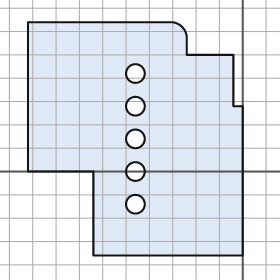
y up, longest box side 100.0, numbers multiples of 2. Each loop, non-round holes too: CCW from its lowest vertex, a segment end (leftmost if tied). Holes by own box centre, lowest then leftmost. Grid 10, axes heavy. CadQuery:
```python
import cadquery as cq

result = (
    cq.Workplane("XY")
    .moveTo(-64.0, -36.0)
    .lineTo(0.0, -36.0)
    .lineTo(0.0, 28.0)
    .lineTo(-4.0, 28.0)
    .lineTo(-4.0, 50.0)
    .lineTo(-24.0, 50.0)
    .lineTo(-24.0, 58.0)
    .threePointArc((-26.0, 62.0), (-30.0, 64.0))
    .lineTo(-92.0, 64.0)
    .lineTo(-92.0, 0.0)
    .lineTo(-64.0, 0.0)
    .close()
    .moveTo(-46.0, -14.0)
    .circle(4.0)
    .moveTo(-46.0, 0.0)
    .circle(4.0)
    .moveTo(-46.0, 14.0)
    .circle(4.0)
    .moveTo(-46.0, 28.0)
    .circle(4.0)
    .moveTo(-46.0, 42.0)
    .circle(4.0)
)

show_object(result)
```